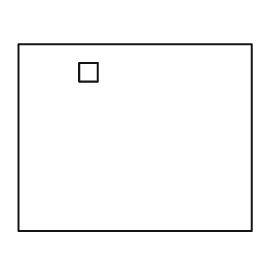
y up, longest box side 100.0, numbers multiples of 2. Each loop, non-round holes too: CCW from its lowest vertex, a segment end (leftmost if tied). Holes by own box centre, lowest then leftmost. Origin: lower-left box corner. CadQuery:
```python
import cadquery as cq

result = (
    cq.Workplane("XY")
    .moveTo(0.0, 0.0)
    .lineTo(100.0, 0.0)
    .lineTo(100.0, 80.0)
    .lineTo(0.0, 80.0)
    .close()
    .moveTo(26.0, 64.0)
    .lineTo(34.0, 64.0)
    .lineTo(34.0, 72.0)
    .lineTo(26.0, 72.0)
    .close()
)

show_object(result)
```